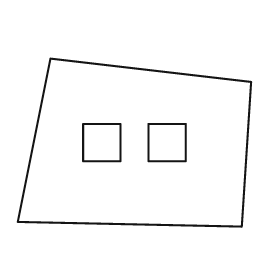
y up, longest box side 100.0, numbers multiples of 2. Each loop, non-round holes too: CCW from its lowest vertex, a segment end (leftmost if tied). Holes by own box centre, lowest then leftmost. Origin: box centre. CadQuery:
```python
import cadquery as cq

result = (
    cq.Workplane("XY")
    .moveTo(46.0, -36.0)
    .lineTo(50.0, 26.0)
    .lineTo(-36.0, 36.0)
    .lineTo(-50.0, -34.0)
    .close()
    .moveTo(-22.0, -8.0)
    .lineTo(-6.0, -8.0)
    .lineTo(-6.0, 8.0)
    .lineTo(-22.0, 8.0)
    .close()
    .moveTo(6.0, -8.0)
    .lineTo(22.0, -8.0)
    .lineTo(22.0, 8.0)
    .lineTo(6.0, 8.0)
    .close()
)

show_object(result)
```